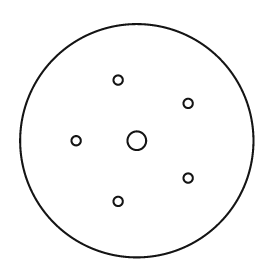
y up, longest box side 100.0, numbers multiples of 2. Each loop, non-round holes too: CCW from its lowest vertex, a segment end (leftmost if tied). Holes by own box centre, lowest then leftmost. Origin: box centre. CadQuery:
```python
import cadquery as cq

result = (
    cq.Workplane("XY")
    .moveTo(0.0, 0.0)
    .circle(50.0)
    .moveTo(-8.0, -26.0)
    .circle(2.0)
    .moveTo(22.0, -16.0)
    .circle(2.0)
    .moveTo(-26.0, 0.0)
    .circle(2.0)
    .moveTo(0.0, 0.0)
    .circle(4.0)
    .moveTo(22.0, 16.0)
    .circle(2.0)
    .moveTo(-8.0, 26.0)
    .circle(2.0)
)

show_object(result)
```